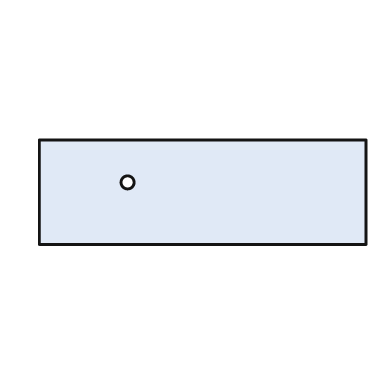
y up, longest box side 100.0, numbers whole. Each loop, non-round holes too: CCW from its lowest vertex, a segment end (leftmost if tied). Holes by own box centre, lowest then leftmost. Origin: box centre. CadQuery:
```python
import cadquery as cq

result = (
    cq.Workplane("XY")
    .moveTo(-50.0, -16.0)
    .lineTo(50.0, -16.0)
    .lineTo(50.0, 16.0)
    .lineTo(-50.0, 16.0)
    .close()
    .moveTo(-23.0, 3.0)
    .circle(2.0)
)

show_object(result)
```